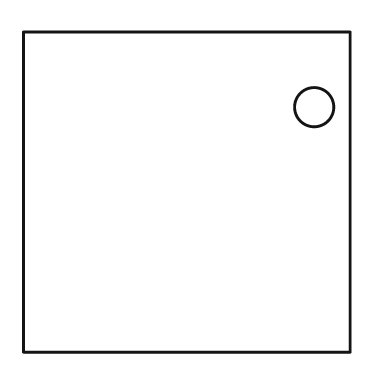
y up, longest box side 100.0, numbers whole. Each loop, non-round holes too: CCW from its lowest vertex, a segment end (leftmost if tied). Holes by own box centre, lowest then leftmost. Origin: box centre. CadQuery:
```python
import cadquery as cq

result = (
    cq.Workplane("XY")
    .moveTo(-50.0, -49.0)
    .lineTo(50.0, -49.0)
    .lineTo(50.0, 49.0)
    .lineTo(-50.0, 49.0)
    .close()
    .moveTo(39.0, 26.0)
    .circle(6.0)
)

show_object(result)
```